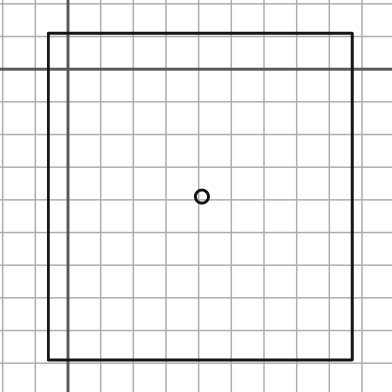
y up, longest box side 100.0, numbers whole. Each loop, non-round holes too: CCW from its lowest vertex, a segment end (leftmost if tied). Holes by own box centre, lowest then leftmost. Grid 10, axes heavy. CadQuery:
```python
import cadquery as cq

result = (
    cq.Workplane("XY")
    .moveTo(-6.0, -89.0)
    .lineTo(87.0, -89.0)
    .lineTo(87.0, 11.0)
    .lineTo(-6.0, 11.0)
    .close()
    .moveTo(41.0, -39.0)
    .circle(2.0)
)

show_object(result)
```